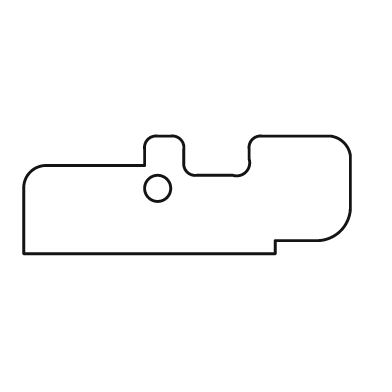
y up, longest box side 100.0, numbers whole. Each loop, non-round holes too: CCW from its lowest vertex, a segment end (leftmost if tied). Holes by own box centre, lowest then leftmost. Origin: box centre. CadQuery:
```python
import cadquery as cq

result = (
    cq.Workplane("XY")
    .moveTo(-50.0, -18.0)
    .lineTo(27.0, -18.0)
    .lineTo(27.0, -14.0)
    .lineTo(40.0, -14.0)
    .threePointArc((47.0, -11.0), (50.0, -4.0))
    .lineTo(50.0, 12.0)
    .threePointArc((48.0, 16.0), (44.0, 18.0))
    .lineTo(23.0, 18.0)
    .threePointArc((20.0, 17.0), (19.0, 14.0))
    .lineTo(19.0, 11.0)
    .threePointArc((18.0, 7.0), (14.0, 6.0))
    .lineTo(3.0, 6.0)
    .threePointArc((0.0, 7.0), (-1.0, 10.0))
    .lineTo(-1.0, 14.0)
    .threePointArc((-2.0, 17.0), (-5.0, 18.0))
    .lineTo(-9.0, 18.0)
    .threePointArc((-12.0, 17.0), (-13.0, 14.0))
    .lineTo(-13.0, 9.0)
    .lineTo(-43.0, 9.0)
    .threePointArc((-48.0, 7.0), (-50.0, 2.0))
    .close()
    .moveTo(-9.0, 2.0)
    .circle(4.0)
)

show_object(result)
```